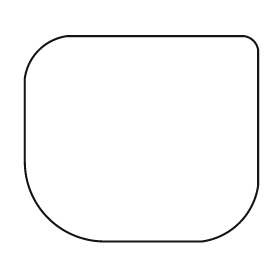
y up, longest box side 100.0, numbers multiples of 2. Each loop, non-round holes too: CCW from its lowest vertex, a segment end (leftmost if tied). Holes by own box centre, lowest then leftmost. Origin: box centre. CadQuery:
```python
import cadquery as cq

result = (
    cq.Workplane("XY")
    .moveTo(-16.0, -44.0)
    .lineTo(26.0, -44.0)
    .threePointArc((42.0, -36.0), (50.0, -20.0))
    .lineTo(50.0, 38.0)
    .threePointArc((48.0, 42.0), (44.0, 44.0))
    .lineTo(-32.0, 44.0)
    .threePointArc((-44.0, 38.0), (-50.0, 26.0))
    .lineTo(-50.0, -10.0)
    .threePointArc((-40.0, -34.0), (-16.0, -44.0))
    .close()
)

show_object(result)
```